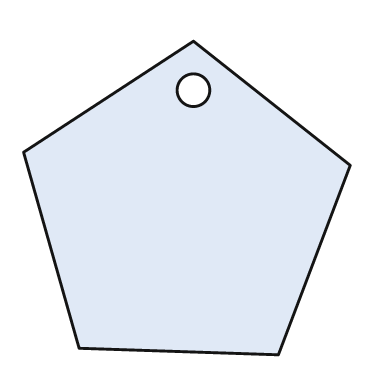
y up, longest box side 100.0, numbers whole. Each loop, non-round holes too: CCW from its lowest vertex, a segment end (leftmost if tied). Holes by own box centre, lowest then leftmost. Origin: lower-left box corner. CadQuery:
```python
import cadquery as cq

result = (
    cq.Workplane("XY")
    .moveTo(78.0, 0.0)
    .lineTo(100.0, 58.0)
    .lineTo(52.0, 96.0)
    .lineTo(0.0, 62.0)
    .lineTo(17.0, 2.0)
    .close()
    .moveTo(52.0, 81.0)
    .circle(5.0)
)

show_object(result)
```